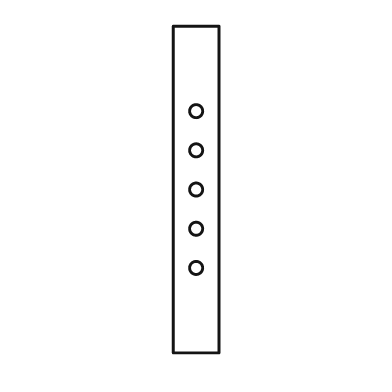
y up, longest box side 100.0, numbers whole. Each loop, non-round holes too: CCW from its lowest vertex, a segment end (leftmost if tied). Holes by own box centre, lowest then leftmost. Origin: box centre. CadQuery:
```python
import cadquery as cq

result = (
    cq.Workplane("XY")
    .moveTo(-7.0, -50.0)
    .lineTo(7.0, -50.0)
    .lineTo(7.0, 50.0)
    .lineTo(-7.0, 50.0)
    .close()
    .moveTo(0.0, -24.0)
    .circle(2.0)
    .moveTo(0.0, -12.0)
    .circle(2.0)
    .moveTo(0.0, 0.0)
    .circle(2.0)
    .moveTo(0.0, 12.0)
    .circle(2.0)
    .moveTo(0.0, 24.0)
    .circle(2.0)
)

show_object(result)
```